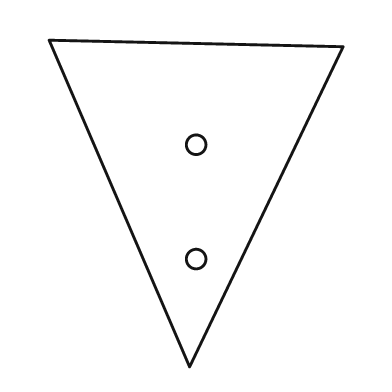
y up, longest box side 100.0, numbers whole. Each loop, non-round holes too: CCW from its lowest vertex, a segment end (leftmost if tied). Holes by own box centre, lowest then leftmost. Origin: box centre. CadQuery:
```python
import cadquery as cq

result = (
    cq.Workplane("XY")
    .moveTo(-2.0, -50.0)
    .lineTo(45.0, 48.0)
    .lineTo(-45.0, 50.0)
    .close()
    .moveTo(0.0, -17.0)
    .circle(3.0)
    .moveTo(0.0, 18.0)
    .circle(3.0)
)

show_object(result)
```